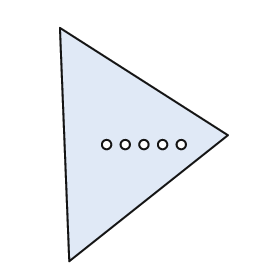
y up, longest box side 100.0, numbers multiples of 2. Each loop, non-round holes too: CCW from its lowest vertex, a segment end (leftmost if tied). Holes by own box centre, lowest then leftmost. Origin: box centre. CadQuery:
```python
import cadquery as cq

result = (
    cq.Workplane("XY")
    .moveTo(-32.0, -50.0)
    .lineTo(36.0, 4.0)
    .lineTo(-36.0, 50.0)
    .close()
    .moveTo(-16.0, 0.0)
    .circle(2.0)
    .moveTo(-8.0, 0.0)
    .circle(2.0)
    .moveTo(0.0, 0.0)
    .circle(2.0)
    .moveTo(8.0, 0.0)
    .circle(2.0)
    .moveTo(16.0, 0.0)
    .circle(2.0)
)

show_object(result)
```